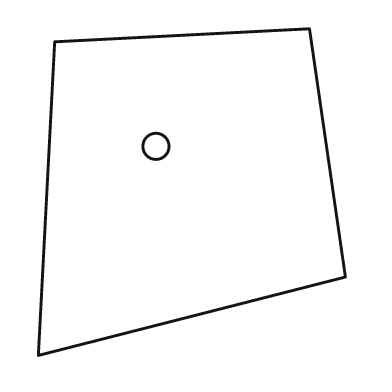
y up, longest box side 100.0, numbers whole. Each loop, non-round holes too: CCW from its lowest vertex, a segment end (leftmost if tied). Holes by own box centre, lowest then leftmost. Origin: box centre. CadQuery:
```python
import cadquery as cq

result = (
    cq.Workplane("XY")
    .moveTo(-47.0, -50.0)
    .lineTo(47.0, -26.0)
    .lineTo(36.0, 50.0)
    .lineTo(-42.0, 46.0)
    .close()
    .moveTo(-11.0, 14.0)
    .circle(4.0)
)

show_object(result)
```